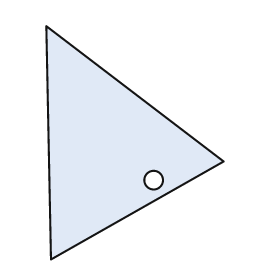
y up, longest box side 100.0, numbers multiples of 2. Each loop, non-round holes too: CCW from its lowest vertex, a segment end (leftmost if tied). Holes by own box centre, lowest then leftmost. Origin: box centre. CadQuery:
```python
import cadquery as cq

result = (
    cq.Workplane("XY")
    .moveTo(-36.0, -50.0)
    .lineTo(38.0, -8.0)
    .lineTo(-38.0, 50.0)
    .close()
    .moveTo(8.0, -16.0)
    .circle(4.0)
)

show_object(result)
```